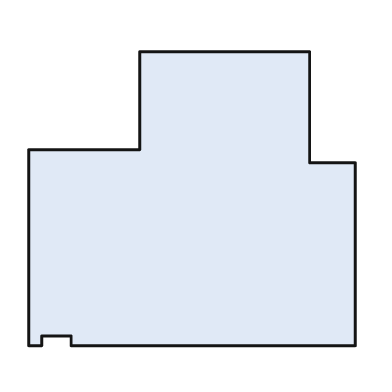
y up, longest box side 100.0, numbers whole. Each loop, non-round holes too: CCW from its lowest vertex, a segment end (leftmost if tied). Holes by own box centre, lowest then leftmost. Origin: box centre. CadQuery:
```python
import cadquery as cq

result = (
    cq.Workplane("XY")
    .moveTo(-50.0, -45.0)
    .lineTo(-46.0, -45.0)
    .lineTo(-46.0, -42.0)
    .lineTo(-37.0, -42.0)
    .lineTo(-37.0, -45.0)
    .lineTo(50.0, -45.0)
    .lineTo(50.0, 11.0)
    .lineTo(36.0, 11.0)
    .lineTo(36.0, 45.0)
    .lineTo(-16.0, 45.0)
    .lineTo(-16.0, 15.0)
    .lineTo(-50.0, 15.0)
    .close()
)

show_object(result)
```